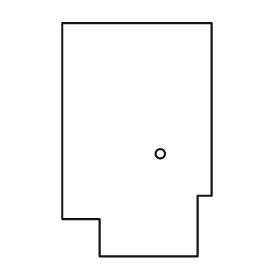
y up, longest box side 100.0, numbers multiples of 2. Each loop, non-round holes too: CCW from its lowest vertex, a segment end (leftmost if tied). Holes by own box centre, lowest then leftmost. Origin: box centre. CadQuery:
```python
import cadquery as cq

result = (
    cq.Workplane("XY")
    .moveTo(-16.0, -50.0)
    .lineTo(26.0, -50.0)
    .lineTo(26.0, -24.0)
    .lineTo(32.0, -24.0)
    .lineTo(32.0, 50.0)
    .lineTo(-32.0, 50.0)
    .lineTo(-32.0, -34.0)
    .lineTo(-16.0, -34.0)
    .close()
    .moveTo(10.0, -6.0)
    .circle(2.0)
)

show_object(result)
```